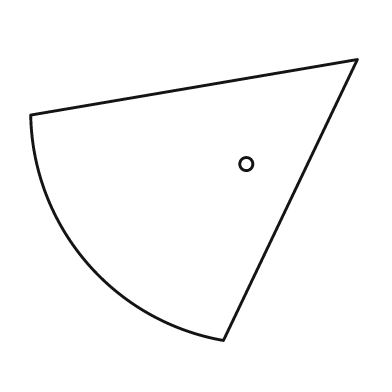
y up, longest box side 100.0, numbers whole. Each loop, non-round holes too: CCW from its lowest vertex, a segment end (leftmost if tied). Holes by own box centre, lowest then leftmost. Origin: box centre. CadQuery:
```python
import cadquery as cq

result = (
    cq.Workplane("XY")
    .moveTo(9.0, -43.0)
    .lineTo(50.0, 43.0)
    .lineTo(-50.0, 26.0)
    .threePointArc((-33.0, -19.0), (9.0, -43.0))
    .close()
    .moveTo(16.0, 11.0)
    .circle(2.0)
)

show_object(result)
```